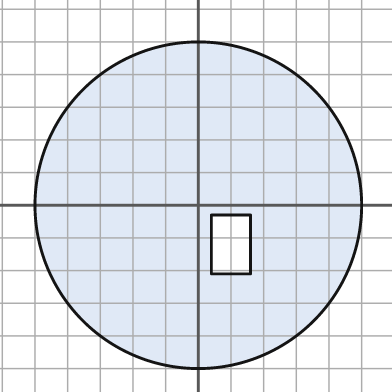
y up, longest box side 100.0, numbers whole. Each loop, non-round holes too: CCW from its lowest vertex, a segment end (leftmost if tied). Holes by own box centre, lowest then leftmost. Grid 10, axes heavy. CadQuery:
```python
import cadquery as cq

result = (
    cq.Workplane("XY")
    .moveTo(0.0, 0.0)
    .circle(50.0)
    .moveTo(4.0, -21.0)
    .lineTo(16.0, -21.0)
    .lineTo(16.0, -3.0)
    .lineTo(4.0, -3.0)
    .close()
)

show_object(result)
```